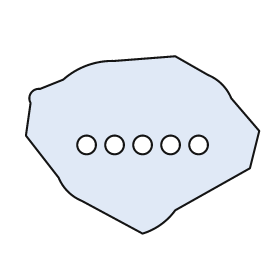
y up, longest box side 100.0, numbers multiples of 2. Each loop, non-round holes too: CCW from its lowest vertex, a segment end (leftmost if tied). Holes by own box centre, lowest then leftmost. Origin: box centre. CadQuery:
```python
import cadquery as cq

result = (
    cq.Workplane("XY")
    .moveTo(0.0, -38.0)
    .threePointArc((8.0, -34.0), (14.0, -28.0))
    .lineTo(46.0, -10.0)
    .lineTo(50.0, 6.0)
    .lineTo(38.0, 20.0)
    .threePointArc((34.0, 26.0), (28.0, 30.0))
    .lineTo(14.0, 38.0)
    .lineTo(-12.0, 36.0)
    .threePointArc((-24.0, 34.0), (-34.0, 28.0))
    .lineTo(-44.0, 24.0)
    .threePointArc((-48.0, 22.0), (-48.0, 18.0))
    .lineTo(-50.0, 4.0)
    .lineTo(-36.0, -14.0)
    .threePointArc((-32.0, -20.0), (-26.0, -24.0))
    .close()
    .moveTo(-24.0, 0.0)
    .circle(4.0)
    .moveTo(-12.0, 0.0)
    .circle(4.0)
    .moveTo(0.0, 0.0)
    .circle(4.0)
    .moveTo(12.0, 0.0)
    .circle(4.0)
    .moveTo(24.0, 0.0)
    .circle(4.0)
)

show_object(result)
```